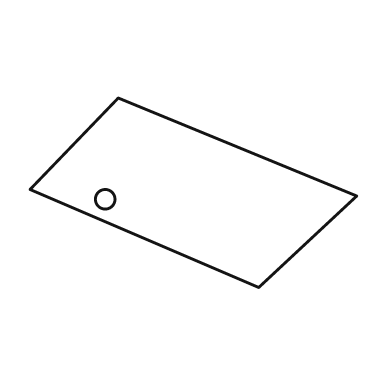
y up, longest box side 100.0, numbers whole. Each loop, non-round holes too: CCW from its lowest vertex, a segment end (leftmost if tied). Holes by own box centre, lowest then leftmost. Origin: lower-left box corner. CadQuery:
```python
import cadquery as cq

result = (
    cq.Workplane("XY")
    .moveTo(70.0, 0.0)
    .lineTo(100.0, 28.0)
    .lineTo(27.0, 58.0)
    .lineTo(0.0, 30.0)
    .close()
    .moveTo(23.0, 27.0)
    .circle(3.0)
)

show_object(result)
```